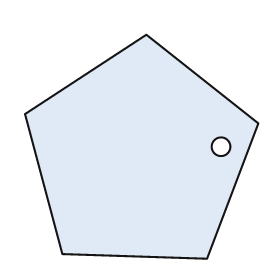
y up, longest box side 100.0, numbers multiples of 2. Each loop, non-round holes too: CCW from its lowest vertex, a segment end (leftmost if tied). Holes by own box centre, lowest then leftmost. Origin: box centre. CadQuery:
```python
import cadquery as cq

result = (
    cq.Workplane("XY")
    .moveTo(28.0, -48.0)
    .lineTo(50.0, 10.0)
    .lineTo(2.0, 48.0)
    .lineTo(-50.0, 14.0)
    .lineTo(-34.0, -46.0)
    .close()
    .moveTo(34.0, 0.0)
    .circle(4.0)
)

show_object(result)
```